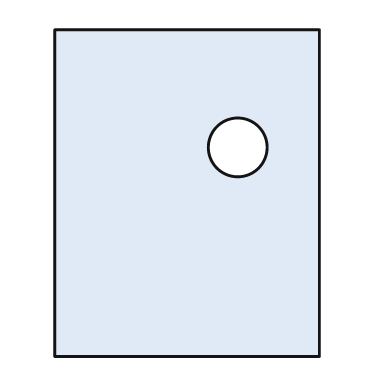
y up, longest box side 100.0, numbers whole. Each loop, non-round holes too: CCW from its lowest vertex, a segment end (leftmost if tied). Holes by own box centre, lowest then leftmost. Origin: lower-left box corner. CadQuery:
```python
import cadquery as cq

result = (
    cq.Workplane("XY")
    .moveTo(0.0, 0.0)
    .lineTo(81.0, 0.0)
    .lineTo(81.0, 100.0)
    .lineTo(0.0, 100.0)
    .close()
    .moveTo(56.0, 64.0)
    .circle(9.0)
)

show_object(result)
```